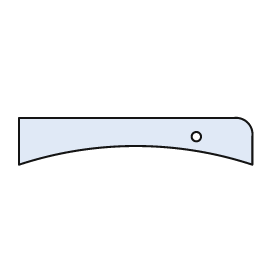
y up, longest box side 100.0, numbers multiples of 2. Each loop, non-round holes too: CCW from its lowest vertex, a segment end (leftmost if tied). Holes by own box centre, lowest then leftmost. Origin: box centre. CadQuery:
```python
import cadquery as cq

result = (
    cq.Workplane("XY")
    .moveTo(-50.0, -10.0)
    .threePointArc((0.0, -2.0), (50.0, -10.0))
    .lineTo(50.0, 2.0)
    .threePointArc((48.0, 8.0), (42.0, 10.0))
    .lineTo(-50.0, 10.0)
    .close()
    .moveTo(26.0, 2.0)
    .circle(2.0)
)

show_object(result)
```